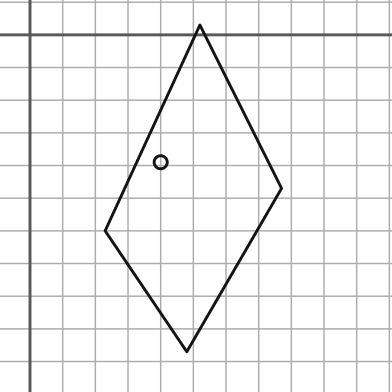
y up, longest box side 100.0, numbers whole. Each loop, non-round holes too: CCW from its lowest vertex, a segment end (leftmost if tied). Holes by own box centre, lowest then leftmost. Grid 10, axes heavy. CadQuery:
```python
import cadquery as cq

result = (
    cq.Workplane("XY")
    .moveTo(48.0, -97.0)
    .lineTo(77.0, -47.0)
    .lineTo(52.0, 3.0)
    .lineTo(23.0, -60.0)
    .close()
    .moveTo(40.0, -39.0)
    .circle(2.0)
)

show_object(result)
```